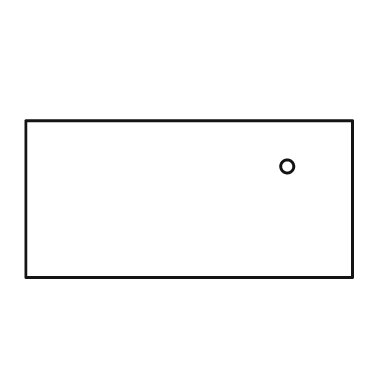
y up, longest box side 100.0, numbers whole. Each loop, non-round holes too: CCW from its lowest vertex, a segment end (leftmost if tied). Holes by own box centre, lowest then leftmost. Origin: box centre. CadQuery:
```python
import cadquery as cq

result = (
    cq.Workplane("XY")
    .moveTo(-50.0, -24.0)
    .lineTo(50.0, -24.0)
    .lineTo(50.0, 24.0)
    .lineTo(-50.0, 24.0)
    .close()
    .moveTo(30.0, 10.0)
    .circle(2.0)
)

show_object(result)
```